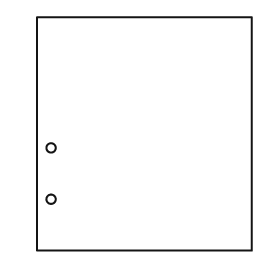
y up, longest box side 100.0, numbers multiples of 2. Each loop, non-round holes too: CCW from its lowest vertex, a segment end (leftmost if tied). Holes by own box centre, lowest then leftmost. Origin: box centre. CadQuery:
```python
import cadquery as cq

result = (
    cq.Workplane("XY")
    .moveTo(-46.0, -50.0)
    .lineTo(46.0, -50.0)
    .lineTo(46.0, 50.0)
    .lineTo(-46.0, 50.0)
    .close()
    .moveTo(-40.0, -28.0)
    .circle(2.0)
    .moveTo(-40.0, -6.0)
    .circle(2.0)
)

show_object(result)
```